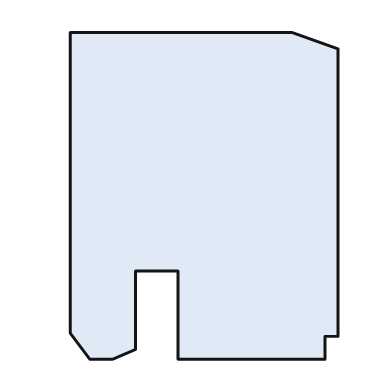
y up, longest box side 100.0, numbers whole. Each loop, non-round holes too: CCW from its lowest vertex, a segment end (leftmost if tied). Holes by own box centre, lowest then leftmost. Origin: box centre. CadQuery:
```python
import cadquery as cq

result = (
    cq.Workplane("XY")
    .moveTo(-35.0, -50.0)
    .lineTo(-28.0, -50.0)
    .lineTo(-21.0, -47.0)
    .lineTo(-21.0, -23.0)
    .lineTo(-8.0, -23.0)
    .lineTo(-8.0, -50.0)
    .lineTo(37.0, -50.0)
    .lineTo(37.0, -43.0)
    .lineTo(41.0, -43.0)
    .lineTo(41.0, 45.0)
    .lineTo(27.0, 50.0)
    .lineTo(-41.0, 50.0)
    .lineTo(-41.0, -42.0)
    .close()
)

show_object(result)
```